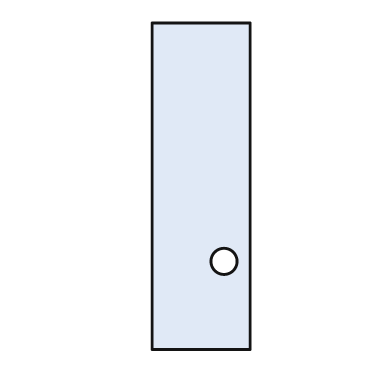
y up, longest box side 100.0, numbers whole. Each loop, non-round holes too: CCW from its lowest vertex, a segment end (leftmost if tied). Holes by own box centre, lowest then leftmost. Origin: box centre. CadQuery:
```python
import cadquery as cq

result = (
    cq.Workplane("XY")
    .moveTo(-15.0, -50.0)
    .lineTo(15.0, -50.0)
    .lineTo(15.0, 50.0)
    .lineTo(-15.0, 50.0)
    .close()
    .moveTo(7.0, -23.0)
    .circle(4.0)
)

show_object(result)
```